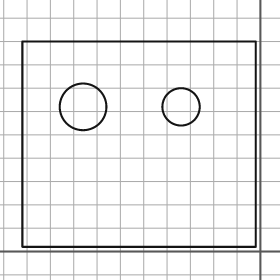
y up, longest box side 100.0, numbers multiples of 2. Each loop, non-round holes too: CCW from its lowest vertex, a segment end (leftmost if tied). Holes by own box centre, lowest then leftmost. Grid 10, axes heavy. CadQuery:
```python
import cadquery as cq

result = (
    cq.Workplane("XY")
    .moveTo(-102.0, 2.0)
    .lineTo(-2.0, 2.0)
    .lineTo(-2.0, 90.0)
    .lineTo(-102.0, 90.0)
    .close()
    .moveTo(-76.0, 62.0)
    .circle(10.0)
    .moveTo(-34.0, 62.0)
    .circle(8.0)
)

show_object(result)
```